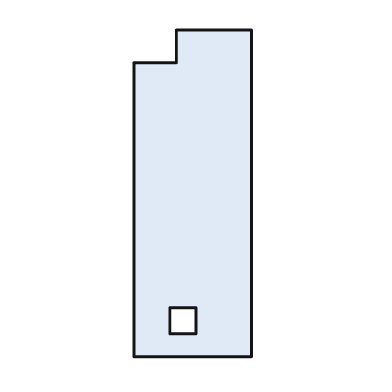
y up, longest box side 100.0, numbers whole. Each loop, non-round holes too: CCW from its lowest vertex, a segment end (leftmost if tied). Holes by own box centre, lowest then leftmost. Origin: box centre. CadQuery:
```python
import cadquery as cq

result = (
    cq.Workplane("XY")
    .moveTo(-18.0, -50.0)
    .lineTo(18.0, -50.0)
    .lineTo(18.0, 50.0)
    .lineTo(-5.0, 50.0)
    .lineTo(-5.0, 40.0)
    .lineTo(-18.0, 40.0)
    .close()
    .moveTo(-7.0, -43.0)
    .lineTo(1.0, -43.0)
    .lineTo(1.0, -35.0)
    .lineTo(-7.0, -35.0)
    .close()
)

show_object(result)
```